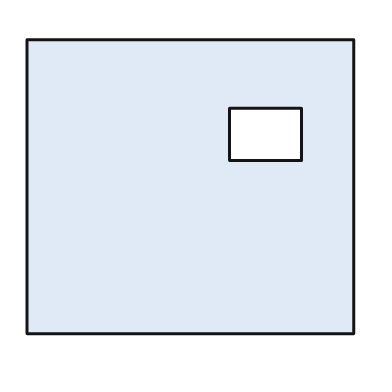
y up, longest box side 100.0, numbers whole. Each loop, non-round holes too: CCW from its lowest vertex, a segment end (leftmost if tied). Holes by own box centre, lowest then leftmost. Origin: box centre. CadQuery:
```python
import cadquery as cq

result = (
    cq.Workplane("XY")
    .moveTo(-50.0, -45.0)
    .lineTo(50.0, -45.0)
    .lineTo(50.0, 45.0)
    .lineTo(-50.0, 45.0)
    .close()
    .moveTo(12.0, 8.0)
    .lineTo(34.0, 8.0)
    .lineTo(34.0, 24.0)
    .lineTo(12.0, 24.0)
    .close()
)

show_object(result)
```